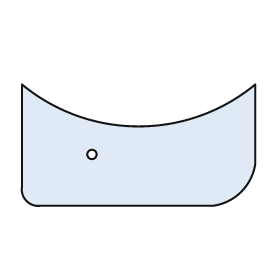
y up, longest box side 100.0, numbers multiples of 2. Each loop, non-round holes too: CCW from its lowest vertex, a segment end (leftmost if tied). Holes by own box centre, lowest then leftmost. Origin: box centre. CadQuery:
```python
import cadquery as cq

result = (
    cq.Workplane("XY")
    .moveTo(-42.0, -26.0)
    .lineTo(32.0, -26.0)
    .threePointArc((44.0, -20.0), (50.0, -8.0))
    .lineTo(50.0, 26.0)
    .threePointArc((0.0, 8.0), (-50.0, 26.0))
    .lineTo(-50.0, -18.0)
    .threePointArc((-48.0, -24.0), (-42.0, -26.0))
    .close()
    .moveTo(-20.0, -4.0)
    .circle(2.0)
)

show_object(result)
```